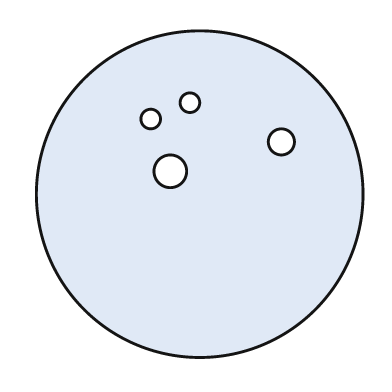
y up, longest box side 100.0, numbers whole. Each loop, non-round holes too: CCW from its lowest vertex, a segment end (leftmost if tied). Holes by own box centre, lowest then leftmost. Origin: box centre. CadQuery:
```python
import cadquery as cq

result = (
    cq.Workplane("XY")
    .moveTo(0.0, 0.0)
    .circle(50.0)
    .moveTo(-9.0, 7.0)
    .circle(5.0)
    .moveTo(25.0, 16.0)
    .circle(4.0)
    .moveTo(-15.0, 23.0)
    .circle(3.0)
    .moveTo(-3.0, 28.0)
    .circle(3.0)
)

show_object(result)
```